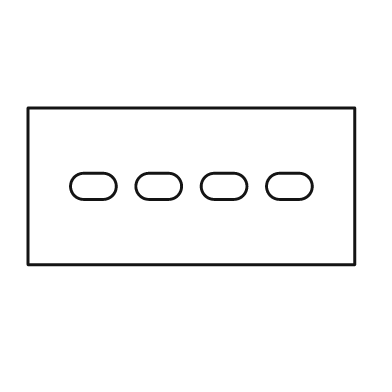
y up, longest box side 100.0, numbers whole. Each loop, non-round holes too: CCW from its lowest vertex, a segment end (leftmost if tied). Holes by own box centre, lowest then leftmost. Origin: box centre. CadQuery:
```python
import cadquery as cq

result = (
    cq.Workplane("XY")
    .moveTo(-50.0, -24.0)
    .lineTo(50.0, -24.0)
    .lineTo(50.0, 24.0)
    .lineTo(-50.0, 24.0)
    .close()
    .moveTo(-33.0, -4.0)
    .lineTo(-27.0, -4.0)
    .threePointArc((-23.0, 0.0), (-27.0, 4.0))
    .lineTo(-33.0, 4.0)
    .threePointArc((-37.0, 0.0), (-33.0, -4.0))
    .close()
    .moveTo(-13.0, -4.0)
    .lineTo(-7.0, -4.0)
    .threePointArc((-3.0, 0.0), (-7.0, 4.0))
    .lineTo(-13.0, 4.0)
    .threePointArc((-17.0, 0.0), (-13.0, -4.0))
    .close()
    .moveTo(7.0, -4.0)
    .lineTo(13.0, -4.0)
    .threePointArc((17.0, 0.0), (13.0, 4.0))
    .lineTo(7.0, 4.0)
    .threePointArc((3.0, 0.0), (7.0, -4.0))
    .close()
    .moveTo(27.0, -4.0)
    .lineTo(33.0, -4.0)
    .threePointArc((37.0, 0.0), (33.0, 4.0))
    .lineTo(27.0, 4.0)
    .threePointArc((23.0, 0.0), (27.0, -4.0))
    .close()
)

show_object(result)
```